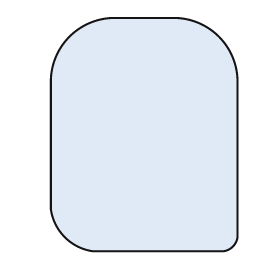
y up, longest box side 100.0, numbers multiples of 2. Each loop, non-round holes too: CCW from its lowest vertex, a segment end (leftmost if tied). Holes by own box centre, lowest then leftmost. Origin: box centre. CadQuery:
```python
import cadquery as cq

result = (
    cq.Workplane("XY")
    .moveTo(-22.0, -50.0)
    .lineTo(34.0, -50.0)
    .threePointArc((38.0, -48.0), (40.0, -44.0))
    .lineTo(40.0, 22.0)
    .threePointArc((32.0, 42.0), (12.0, 50.0))
    .lineTo(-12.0, 50.0)
    .threePointArc((-32.0, 42.0), (-40.0, 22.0))
    .lineTo(-40.0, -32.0)
    .threePointArc((-34.0, -44.0), (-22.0, -50.0))
    .close()
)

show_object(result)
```